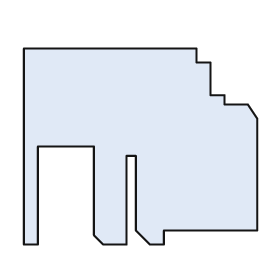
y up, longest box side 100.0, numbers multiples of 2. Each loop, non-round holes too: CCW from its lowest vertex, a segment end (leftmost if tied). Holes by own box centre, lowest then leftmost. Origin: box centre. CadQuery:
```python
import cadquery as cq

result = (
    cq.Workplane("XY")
    .moveTo(-50.0, -42.0)
    .lineTo(-44.0, -42.0)
    .lineTo(-44.0, 0.0)
    .lineTo(-20.0, 0.0)
    .lineTo(-20.0, -38.0)
    .lineTo(-16.0, -42.0)
    .lineTo(-6.0, -42.0)
    .lineTo(-6.0, -4.0)
    .lineTo(-2.0, -4.0)
    .lineTo(-2.0, -36.0)
    .lineTo(4.0, -42.0)
    .lineTo(10.0, -42.0)
    .lineTo(10.0, -36.0)
    .lineTo(50.0, -36.0)
    .lineTo(50.0, 12.0)
    .lineTo(46.0, 18.0)
    .lineTo(36.0, 18.0)
    .lineTo(36.0, 22.0)
    .lineTo(30.0, 22.0)
    .lineTo(30.0, 36.0)
    .lineTo(24.0, 36.0)
    .lineTo(24.0, 42.0)
    .lineTo(-50.0, 42.0)
    .close()
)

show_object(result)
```